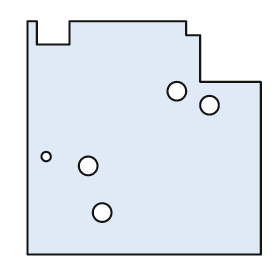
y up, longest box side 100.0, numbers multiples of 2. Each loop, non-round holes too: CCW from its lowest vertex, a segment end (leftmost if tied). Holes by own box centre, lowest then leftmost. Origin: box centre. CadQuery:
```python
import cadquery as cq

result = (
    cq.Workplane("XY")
    .moveTo(-50.0, -50.0)
    .lineTo(50.0, -50.0)
    .lineTo(50.0, 24.0)
    .lineTo(24.0, 24.0)
    .lineTo(24.0, 44.0)
    .lineTo(18.0, 44.0)
    .lineTo(18.0, 50.0)
    .lineTo(-32.0, 50.0)
    .lineTo(-32.0, 40.0)
    .lineTo(-46.0, 40.0)
    .lineTo(-46.0, 50.0)
    .lineTo(-50.0, 50.0)
    .close()
    .moveTo(-18.0, -32.0)
    .circle(4.0)
    .moveTo(-24.0, -12.0)
    .circle(4.0)
    .moveTo(-42.0, -8.0)
    .circle(2.0)
    .moveTo(28.0, 14.0)
    .circle(4.0)
    .moveTo(14.0, 20.0)
    .circle(4.0)
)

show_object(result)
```